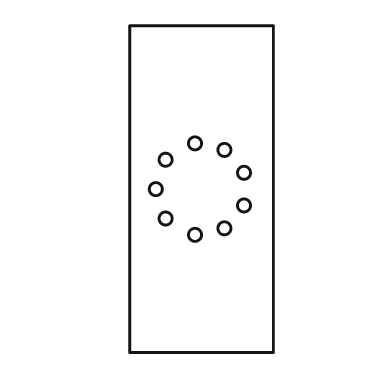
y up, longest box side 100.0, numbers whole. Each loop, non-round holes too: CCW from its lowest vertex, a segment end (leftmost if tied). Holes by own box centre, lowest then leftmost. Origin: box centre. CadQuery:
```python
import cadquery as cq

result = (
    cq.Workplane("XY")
    .moveTo(-22.0, -50.0)
    .lineTo(22.0, -50.0)
    .lineTo(22.0, 50.0)
    .lineTo(-22.0, 50.0)
    .close()
    .moveTo(-2.0, -14.0)
    .circle(2.0)
    .moveTo(7.0, -12.0)
    .circle(2.0)
    .moveTo(-11.0, -9.0)
    .circle(2.0)
    .moveTo(13.0, -5.0)
    .circle(2.0)
    .moveTo(-14.0, 0.0)
    .circle(2.0)
    .moveTo(13.0, 5.0)
    .circle(2.0)
    .moveTo(-11.0, 9.0)
    .circle(2.0)
    .moveTo(7.0, 12.0)
    .circle(2.0)
    .moveTo(-2.0, 14.0)
    .circle(2.0)
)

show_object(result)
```